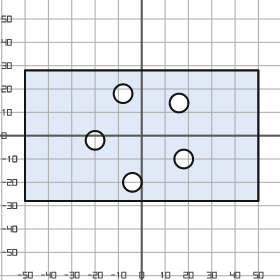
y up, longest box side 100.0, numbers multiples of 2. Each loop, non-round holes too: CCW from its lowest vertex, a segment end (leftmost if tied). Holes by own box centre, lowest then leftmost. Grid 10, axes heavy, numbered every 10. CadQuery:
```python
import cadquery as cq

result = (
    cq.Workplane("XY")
    .moveTo(-50.0, -28.0)
    .lineTo(50.0, -28.0)
    .lineTo(50.0, 28.0)
    .lineTo(-50.0, 28.0)
    .close()
    .moveTo(-4.0, -20.0)
    .circle(4.0)
    .moveTo(18.0, -10.0)
    .circle(4.0)
    .moveTo(-20.0, -2.0)
    .circle(4.0)
    .moveTo(16.0, 14.0)
    .circle(4.0)
    .moveTo(-8.0, 18.0)
    .circle(4.0)
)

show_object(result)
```